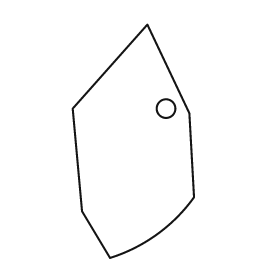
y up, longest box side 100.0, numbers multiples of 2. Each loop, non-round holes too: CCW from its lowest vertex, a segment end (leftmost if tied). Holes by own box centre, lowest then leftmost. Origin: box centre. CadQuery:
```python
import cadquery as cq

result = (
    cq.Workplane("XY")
    .moveTo(-10.0, -50.0)
    .threePointArc((10.0, -40.0), (26.0, -24.0))
    .lineTo(24.0, 12.0)
    .lineTo(6.0, 50.0)
    .lineTo(-26.0, 14.0)
    .lineTo(-22.0, -30.0)
    .close()
    .moveTo(14.0, 14.0)
    .circle(4.0)
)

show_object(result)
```